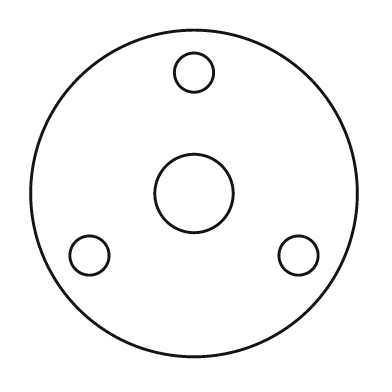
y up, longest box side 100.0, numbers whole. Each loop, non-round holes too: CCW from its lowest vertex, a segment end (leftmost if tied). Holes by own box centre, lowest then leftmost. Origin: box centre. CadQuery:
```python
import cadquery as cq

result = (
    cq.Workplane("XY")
    .moveTo(0.0, 0.0)
    .circle(50.0)
    .moveTo(-32.0, -19.0)
    .circle(6.0)
    .moveTo(32.0, -19.0)
    .circle(6.0)
    .moveTo(0.0, 0.0)
    .circle(12.0)
    .moveTo(0.0, 37.0)
    .circle(6.0)
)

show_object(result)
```